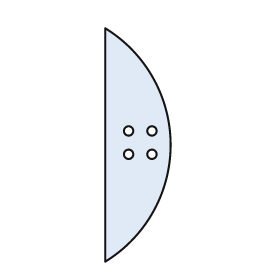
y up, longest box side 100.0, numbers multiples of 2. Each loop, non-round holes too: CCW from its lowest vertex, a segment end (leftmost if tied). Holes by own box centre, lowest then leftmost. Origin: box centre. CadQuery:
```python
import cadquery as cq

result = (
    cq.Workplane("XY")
    .moveTo(-14.0, -50.0)
    .threePointArc((14.0, 0.0), (-14.0, 50.0))
    .close()
    .moveTo(-4.0, -4.0)
    .circle(2.0)
    .moveTo(6.0, -4.0)
    .circle(2.0)
    .moveTo(-4.0, 6.0)
    .circle(2.0)
    .moveTo(6.0, 6.0)
    .circle(2.0)
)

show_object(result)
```